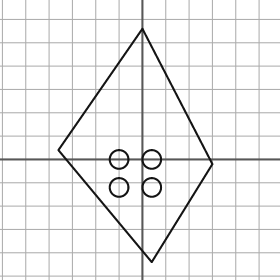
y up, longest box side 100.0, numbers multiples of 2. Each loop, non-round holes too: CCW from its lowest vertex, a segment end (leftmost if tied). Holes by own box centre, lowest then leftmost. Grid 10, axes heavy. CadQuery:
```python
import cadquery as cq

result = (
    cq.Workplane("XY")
    .moveTo(4.0, -44.0)
    .lineTo(30.0, -2.0)
    .lineTo(0.0, 56.0)
    .lineTo(-36.0, 4.0)
    .close()
    .moveTo(-10.0, -12.0)
    .circle(4.0)
    .moveTo(4.0, -12.0)
    .circle(4.0)
    .moveTo(-10.0, 0.0)
    .circle(4.0)
    .moveTo(4.0, 0.0)
    .circle(4.0)
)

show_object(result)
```